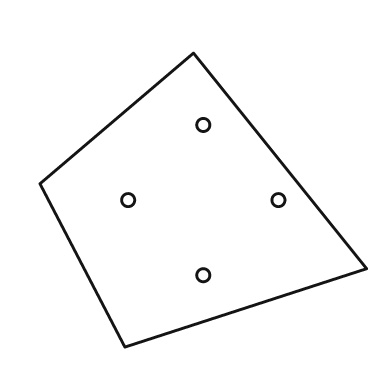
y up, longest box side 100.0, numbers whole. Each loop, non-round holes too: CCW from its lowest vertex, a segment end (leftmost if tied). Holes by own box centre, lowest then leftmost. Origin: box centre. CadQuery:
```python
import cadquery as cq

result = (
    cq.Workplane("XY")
    .moveTo(-24.0, -45.0)
    .lineTo(50.0, -21.0)
    .lineTo(-3.0, 45.0)
    .lineTo(-50.0, 5.0)
    .close()
    .moveTo(0.0, -23.0)
    .circle(2.0)
    .moveTo(-23.0, 0.0)
    .circle(2.0)
    .moveTo(23.0, 0.0)
    .circle(2.0)
    .moveTo(0.0, 23.0)
    .circle(2.0)
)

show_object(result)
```